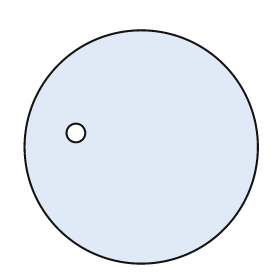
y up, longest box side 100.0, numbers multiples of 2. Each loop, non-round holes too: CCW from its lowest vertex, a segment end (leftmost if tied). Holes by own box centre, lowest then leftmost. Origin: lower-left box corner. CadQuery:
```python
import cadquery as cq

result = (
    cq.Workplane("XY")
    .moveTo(50.0, 50.0)
    .circle(50.0)
    .moveTo(22.0, 56.0)
    .circle(4.0)
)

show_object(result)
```